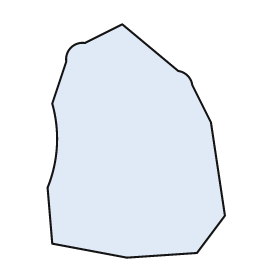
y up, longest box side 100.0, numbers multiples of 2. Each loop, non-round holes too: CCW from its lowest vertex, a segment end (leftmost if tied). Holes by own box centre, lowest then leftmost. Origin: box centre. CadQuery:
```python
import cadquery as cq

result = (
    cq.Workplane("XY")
    .moveTo(-4.0, -50.0)
    .lineTo(26.0, -48.0)
    .lineTo(38.0, -32.0)
    .lineTo(32.0, 8.0)
    .lineTo(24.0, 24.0)
    .threePointArc((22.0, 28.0), (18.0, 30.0))
    .lineTo(-6.0, 50.0)
    .lineTo(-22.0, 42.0)
    .threePointArc((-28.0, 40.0), (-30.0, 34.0))
    .lineTo(-36.0, 16.0)
    .threePointArc((-34.0, -2.0), (-38.0, -20.0))
    .lineTo(-36.0, -44.0)
    .close()
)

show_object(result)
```